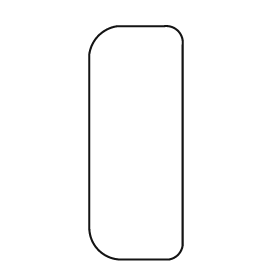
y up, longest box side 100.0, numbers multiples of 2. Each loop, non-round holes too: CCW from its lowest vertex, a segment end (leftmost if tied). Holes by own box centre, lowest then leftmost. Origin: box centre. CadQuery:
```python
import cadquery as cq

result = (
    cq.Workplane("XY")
    .moveTo(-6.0, -50.0)
    .lineTo(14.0, -50.0)
    .threePointArc((18.0, -48.0), (20.0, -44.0))
    .lineTo(20.0, 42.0)
    .threePointArc((18.0, 48.0), (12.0, 50.0))
    .lineTo(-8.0, 50.0)
    .threePointArc((-16.0, 46.0), (-20.0, 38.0))
    .lineTo(-20.0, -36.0)
    .threePointArc((-16.0, -46.0), (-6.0, -50.0))
    .close()
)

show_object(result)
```